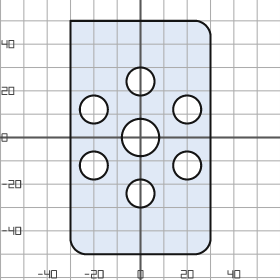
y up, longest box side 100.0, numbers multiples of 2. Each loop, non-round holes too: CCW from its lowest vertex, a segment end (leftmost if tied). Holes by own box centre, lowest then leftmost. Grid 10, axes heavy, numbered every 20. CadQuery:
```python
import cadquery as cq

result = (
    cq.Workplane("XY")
    .moveTo(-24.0, -50.0)
    .lineTo(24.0, -50.0)
    .threePointArc((28.0, -48.0), (30.0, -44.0))
    .lineTo(30.0, 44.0)
    .threePointArc((28.0, 48.0), (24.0, 50.0))
    .lineTo(-30.0, 50.0)
    .lineTo(-30.0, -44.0)
    .threePointArc((-28.0, -48.0), (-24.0, -50.0))
    .close()
    .moveTo(0.0, -24.0)
    .circle(6.0)
    .moveTo(-20.0, -12.0)
    .circle(6.0)
    .moveTo(20.0, -12.0)
    .circle(6.0)
    .moveTo(0.0, 0.0)
    .circle(8.0)
    .moveTo(-20.0, 12.0)
    .circle(6.0)
    .moveTo(20.0, 12.0)
    .circle(6.0)
    .moveTo(0.0, 24.0)
    .circle(6.0)
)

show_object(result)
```